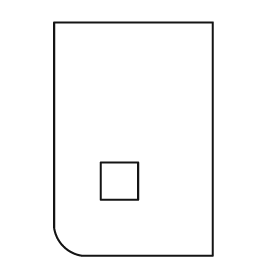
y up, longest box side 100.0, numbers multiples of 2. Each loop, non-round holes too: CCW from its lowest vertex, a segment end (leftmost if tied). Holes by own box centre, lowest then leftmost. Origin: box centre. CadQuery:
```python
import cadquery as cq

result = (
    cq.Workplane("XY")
    .moveTo(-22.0, -50.0)
    .lineTo(34.0, -50.0)
    .lineTo(34.0, 50.0)
    .lineTo(-34.0, 50.0)
    .lineTo(-34.0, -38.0)
    .threePointArc((-30.0, -46.0), (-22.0, -50.0))
    .close()
    .moveTo(-14.0, -26.0)
    .lineTo(2.0, -26.0)
    .lineTo(2.0, -10.0)
    .lineTo(-14.0, -10.0)
    .close()
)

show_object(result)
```